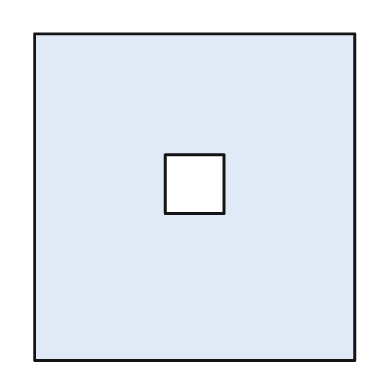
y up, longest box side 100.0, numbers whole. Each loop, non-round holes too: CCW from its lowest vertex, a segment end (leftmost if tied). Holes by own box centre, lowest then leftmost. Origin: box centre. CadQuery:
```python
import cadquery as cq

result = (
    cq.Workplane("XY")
    .moveTo(-49.0, -50.0)
    .lineTo(49.0, -50.0)
    .lineTo(49.0, 50.0)
    .lineTo(-49.0, 50.0)
    .close()
    .moveTo(-9.0, -5.0)
    .lineTo(9.0, -5.0)
    .lineTo(9.0, 13.0)
    .lineTo(-9.0, 13.0)
    .close()
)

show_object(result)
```